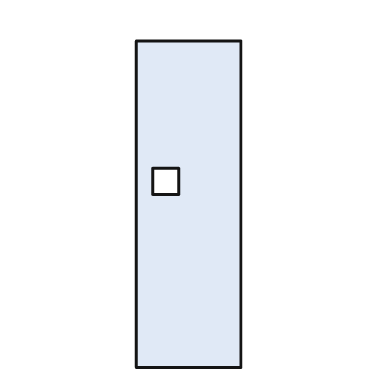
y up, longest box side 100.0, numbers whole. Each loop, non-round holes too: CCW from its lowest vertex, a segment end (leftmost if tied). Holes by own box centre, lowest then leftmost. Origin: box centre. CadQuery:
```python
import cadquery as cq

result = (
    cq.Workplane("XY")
    .moveTo(-16.0, -50.0)
    .lineTo(16.0, -50.0)
    .lineTo(16.0, 50.0)
    .lineTo(-16.0, 50.0)
    .close()
    .moveTo(-11.0, 3.0)
    .lineTo(-3.0, 3.0)
    .lineTo(-3.0, 11.0)
    .lineTo(-11.0, 11.0)
    .close()
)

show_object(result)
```